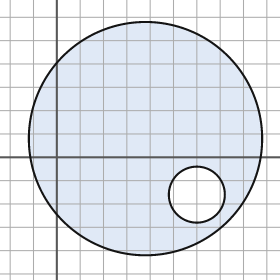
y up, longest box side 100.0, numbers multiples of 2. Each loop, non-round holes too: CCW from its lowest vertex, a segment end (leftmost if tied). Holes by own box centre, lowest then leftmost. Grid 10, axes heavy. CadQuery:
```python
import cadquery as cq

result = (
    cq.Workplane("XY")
    .moveTo(38.0, 8.0)
    .circle(50.0)
    .moveTo(60.0, -16.0)
    .circle(12.0)
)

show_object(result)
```